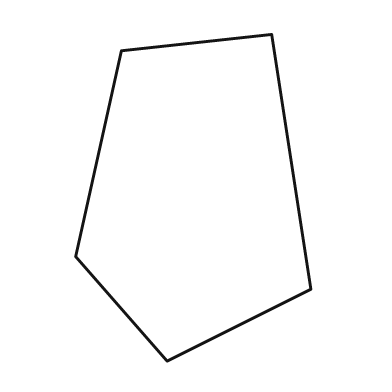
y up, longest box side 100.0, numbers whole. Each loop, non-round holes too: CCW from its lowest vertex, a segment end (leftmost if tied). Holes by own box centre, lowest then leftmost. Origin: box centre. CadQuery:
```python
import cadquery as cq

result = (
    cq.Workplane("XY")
    .moveTo(-8.0, -50.0)
    .lineTo(36.0, -28.0)
    .lineTo(24.0, 50.0)
    .lineTo(-22.0, 45.0)
    .lineTo(-36.0, -18.0)
    .close()
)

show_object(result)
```